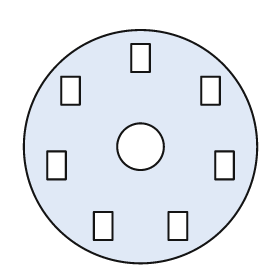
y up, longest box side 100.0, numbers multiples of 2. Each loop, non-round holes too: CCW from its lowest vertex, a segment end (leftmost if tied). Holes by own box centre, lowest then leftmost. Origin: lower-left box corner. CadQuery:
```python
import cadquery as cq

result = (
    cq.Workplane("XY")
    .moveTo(50.0, 50.0)
    .circle(50.0)
    .moveTo(30.0, 10.0)
    .lineTo(38.0, 10.0)
    .lineTo(38.0, 22.0)
    .lineTo(30.0, 22.0)
    .close()
    .moveTo(62.0, 10.0)
    .lineTo(70.0, 10.0)
    .lineTo(70.0, 22.0)
    .lineTo(62.0, 22.0)
    .close()
    .moveTo(10.0, 36.0)
    .lineTo(18.0, 36.0)
    .lineTo(18.0, 48.0)
    .lineTo(10.0, 48.0)
    .close()
    .moveTo(82.0, 36.0)
    .lineTo(90.0, 36.0)
    .lineTo(90.0, 48.0)
    .lineTo(82.0, 48.0)
    .close()
    .moveTo(50.0, 50.0)
    .circle(10.0)
    .moveTo(16.0, 68.0)
    .lineTo(24.0, 68.0)
    .lineTo(24.0, 80.0)
    .lineTo(16.0, 80.0)
    .close()
    .moveTo(76.0, 68.0)
    .lineTo(84.0, 68.0)
    .lineTo(84.0, 80.0)
    .lineTo(76.0, 80.0)
    .close()
    .moveTo(46.0, 82.0)
    .lineTo(54.0, 82.0)
    .lineTo(54.0, 94.0)
    .lineTo(46.0, 94.0)
    .close()
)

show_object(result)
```